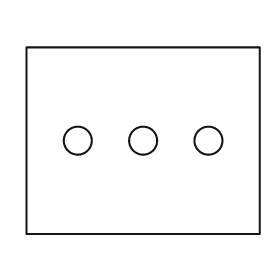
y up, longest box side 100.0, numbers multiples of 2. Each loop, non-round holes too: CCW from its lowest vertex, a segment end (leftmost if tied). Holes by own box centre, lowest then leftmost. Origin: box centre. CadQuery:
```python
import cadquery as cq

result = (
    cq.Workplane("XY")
    .moveTo(-50.0, -40.0)
    .lineTo(50.0, -40.0)
    .lineTo(50.0, 40.0)
    .lineTo(-50.0, 40.0)
    .close()
    .moveTo(-28.0, 0.0)
    .circle(6.0)
    .moveTo(0.0, 0.0)
    .circle(6.0)
    .moveTo(28.0, 0.0)
    .circle(6.0)
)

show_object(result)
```